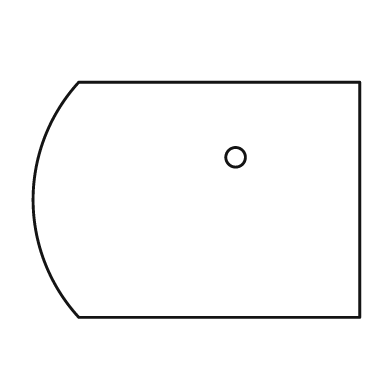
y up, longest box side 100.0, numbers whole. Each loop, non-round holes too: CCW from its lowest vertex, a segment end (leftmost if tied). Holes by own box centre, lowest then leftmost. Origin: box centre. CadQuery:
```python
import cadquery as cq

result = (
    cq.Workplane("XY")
    .moveTo(-36.0, -36.0)
    .lineTo(50.0, -36.0)
    .lineTo(50.0, 36.0)
    .lineTo(-36.0, 36.0)
    .threePointArc((-50.0, 0.0), (-36.0, -36.0))
    .close()
    .moveTo(12.0, 13.0)
    .circle(3.0)
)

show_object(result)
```